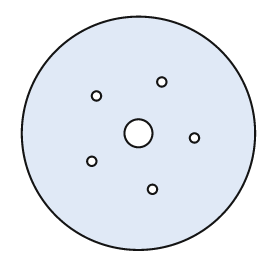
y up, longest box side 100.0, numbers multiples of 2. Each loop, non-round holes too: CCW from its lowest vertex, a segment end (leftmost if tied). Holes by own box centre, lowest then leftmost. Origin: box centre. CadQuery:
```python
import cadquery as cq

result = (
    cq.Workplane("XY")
    .moveTo(0.0, 0.0)
    .circle(50.0)
    .moveTo(6.0, -24.0)
    .circle(2.0)
    .moveTo(-20.0, -12.0)
    .circle(2.0)
    .moveTo(24.0, -2.0)
    .circle(2.0)
    .moveTo(0.0, 0.0)
    .circle(6.0)
    .moveTo(-18.0, 16.0)
    .circle(2.0)
    .moveTo(10.0, 22.0)
    .circle(2.0)
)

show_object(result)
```